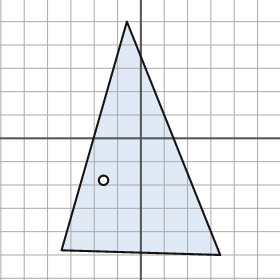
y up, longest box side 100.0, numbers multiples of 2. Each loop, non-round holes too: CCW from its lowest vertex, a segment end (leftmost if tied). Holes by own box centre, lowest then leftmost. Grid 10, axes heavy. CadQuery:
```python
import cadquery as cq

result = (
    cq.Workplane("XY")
    .moveTo(34.0, -50.0)
    .lineTo(-6.0, 50.0)
    .lineTo(-34.0, -48.0)
    .close()
    .moveTo(-16.0, -18.0)
    .circle(2.0)
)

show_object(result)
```